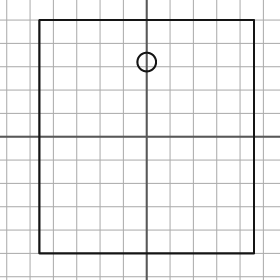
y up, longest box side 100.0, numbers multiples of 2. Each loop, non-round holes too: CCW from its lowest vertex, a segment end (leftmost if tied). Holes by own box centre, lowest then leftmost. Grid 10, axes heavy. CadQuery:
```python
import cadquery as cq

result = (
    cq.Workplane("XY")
    .moveTo(-46.0, -50.0)
    .lineTo(46.0, -50.0)
    .lineTo(46.0, 50.0)
    .lineTo(-46.0, 50.0)
    .close()
    .moveTo(0.0, 32.0)
    .circle(4.0)
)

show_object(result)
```